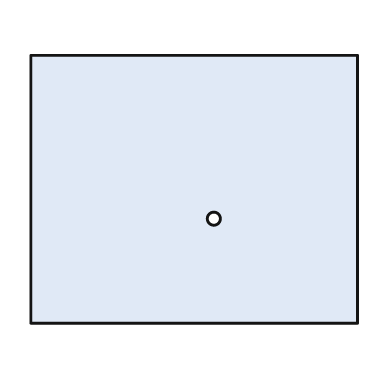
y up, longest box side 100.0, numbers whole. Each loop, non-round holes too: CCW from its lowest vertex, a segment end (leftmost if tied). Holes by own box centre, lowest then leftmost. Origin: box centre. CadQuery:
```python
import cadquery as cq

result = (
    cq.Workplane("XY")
    .moveTo(-50.0, -41.0)
    .lineTo(50.0, -41.0)
    .lineTo(50.0, 41.0)
    .lineTo(-50.0, 41.0)
    .close()
    .moveTo(6.0, -9.0)
    .circle(2.0)
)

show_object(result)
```